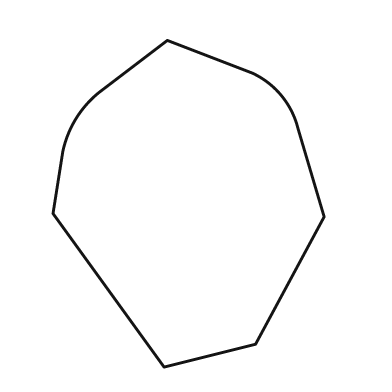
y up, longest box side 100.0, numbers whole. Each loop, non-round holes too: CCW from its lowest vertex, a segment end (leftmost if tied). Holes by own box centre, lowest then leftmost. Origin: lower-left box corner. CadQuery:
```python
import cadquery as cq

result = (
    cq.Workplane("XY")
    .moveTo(34.0, 0.0)
    .lineTo(62.0, 7.0)
    .lineTo(83.0, 46.0)
    .lineTo(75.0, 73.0)
    .threePointArc((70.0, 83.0), (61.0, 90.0))
    .lineTo(35.0, 100.0)
    .lineTo(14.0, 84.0)
    .threePointArc((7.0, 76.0), (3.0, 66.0))
    .lineTo(0.0, 47.0)
    .close()
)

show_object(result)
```